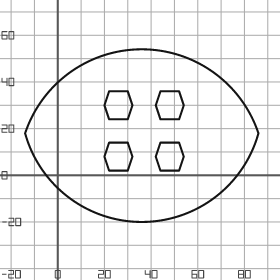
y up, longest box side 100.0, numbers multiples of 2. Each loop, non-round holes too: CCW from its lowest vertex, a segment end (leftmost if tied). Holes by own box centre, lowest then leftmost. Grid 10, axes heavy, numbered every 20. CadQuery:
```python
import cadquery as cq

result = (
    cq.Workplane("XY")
    .moveTo(-14.0, 18.0)
    .threePointArc((36.0, -20.0), (86.0, 18.0))
    .threePointArc((36.0, 54.0), (-14.0, 18.0))
    .close()
    .moveTo(22.0, 2.0)
    .lineTo(30.0, 2.0)
    .lineTo(32.0, 8.0)
    .lineTo(30.0, 14.0)
    .lineTo(22.0, 14.0)
    .lineTo(20.0, 8.0)
    .close()
    .moveTo(44.0, 2.0)
    .lineTo(52.0, 2.0)
    .lineTo(54.0, 8.0)
    .lineTo(52.0, 14.0)
    .lineTo(44.0, 14.0)
    .lineTo(42.0, 8.0)
    .close()
    .moveTo(22.0, 24.0)
    .lineTo(30.0, 24.0)
    .lineTo(32.0, 30.0)
    .lineTo(30.0, 36.0)
    .lineTo(22.0, 36.0)
    .lineTo(20.0, 30.0)
    .close()
    .moveTo(44.0, 24.0)
    .lineTo(52.0, 24.0)
    .lineTo(54.0, 30.0)
    .lineTo(52.0, 36.0)
    .lineTo(44.0, 36.0)
    .lineTo(42.0, 30.0)
    .close()
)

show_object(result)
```